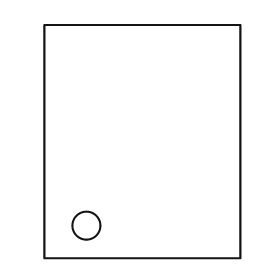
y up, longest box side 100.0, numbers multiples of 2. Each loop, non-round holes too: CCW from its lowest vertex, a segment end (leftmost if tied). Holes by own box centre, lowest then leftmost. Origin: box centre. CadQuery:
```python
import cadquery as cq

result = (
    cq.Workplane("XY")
    .moveTo(-42.0, -50.0)
    .lineTo(42.0, -50.0)
    .lineTo(42.0, 50.0)
    .lineTo(-42.0, 50.0)
    .close()
    .moveTo(-24.0, -36.0)
    .circle(6.0)
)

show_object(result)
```